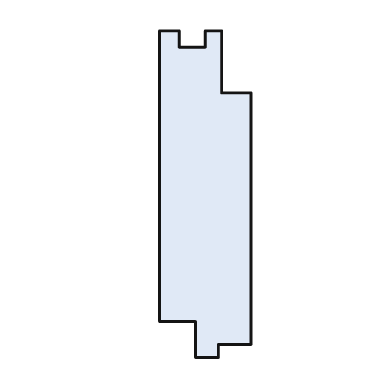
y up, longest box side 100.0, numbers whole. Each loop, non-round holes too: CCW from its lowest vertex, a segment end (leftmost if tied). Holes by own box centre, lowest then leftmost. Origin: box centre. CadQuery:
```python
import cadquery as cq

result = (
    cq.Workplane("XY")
    .moveTo(-3.0, -50.0)
    .lineTo(4.0, -50.0)
    .lineTo(4.0, -46.0)
    .lineTo(14.0, -46.0)
    .lineTo(14.0, 31.0)
    .lineTo(5.0, 31.0)
    .lineTo(5.0, 50.0)
    .lineTo(0.0, 50.0)
    .lineTo(0.0, 45.0)
    .lineTo(-8.0, 45.0)
    .lineTo(-8.0, 50.0)
    .lineTo(-14.0, 50.0)
    .lineTo(-14.0, -39.0)
    .lineTo(-3.0, -39.0)
    .close()
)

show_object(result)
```